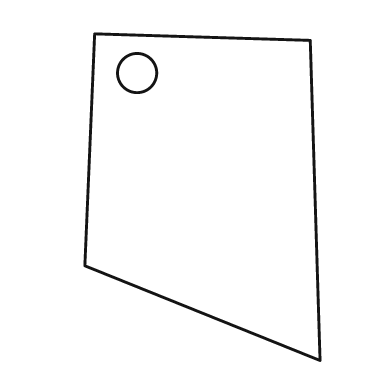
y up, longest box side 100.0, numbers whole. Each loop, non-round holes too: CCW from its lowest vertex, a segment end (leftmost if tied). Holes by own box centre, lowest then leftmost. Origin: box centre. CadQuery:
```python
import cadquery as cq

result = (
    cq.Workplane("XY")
    .moveTo(36.0, -50.0)
    .lineTo(33.0, 48.0)
    .lineTo(-33.0, 50.0)
    .lineTo(-36.0, -21.0)
    .close()
    .moveTo(-20.0, 38.0)
    .circle(6.0)
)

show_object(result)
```